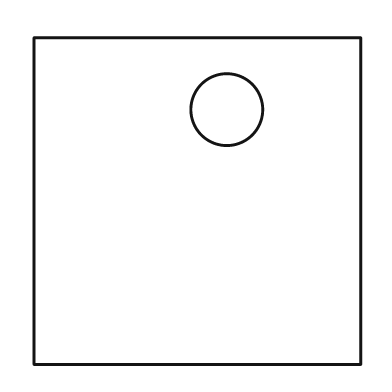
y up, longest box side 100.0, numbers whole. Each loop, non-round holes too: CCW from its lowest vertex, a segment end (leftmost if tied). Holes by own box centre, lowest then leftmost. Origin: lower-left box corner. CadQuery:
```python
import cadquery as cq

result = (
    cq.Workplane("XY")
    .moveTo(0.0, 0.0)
    .lineTo(100.0, 0.0)
    .lineTo(100.0, 100.0)
    .lineTo(0.0, 100.0)
    .close()
    .moveTo(59.0, 78.0)
    .circle(11.0)
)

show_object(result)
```